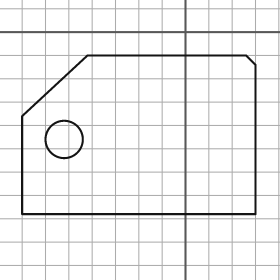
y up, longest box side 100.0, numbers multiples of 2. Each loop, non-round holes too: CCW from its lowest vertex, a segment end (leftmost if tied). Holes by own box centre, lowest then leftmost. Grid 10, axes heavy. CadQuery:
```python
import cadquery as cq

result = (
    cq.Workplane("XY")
    .moveTo(-70.0, -78.0)
    .lineTo(30.0, -78.0)
    .lineTo(30.0, -14.0)
    .lineTo(26.0, -10.0)
    .lineTo(-42.0, -10.0)
    .lineTo(-70.0, -36.0)
    .close()
    .moveTo(-52.0, -46.0)
    .circle(8.0)
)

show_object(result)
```